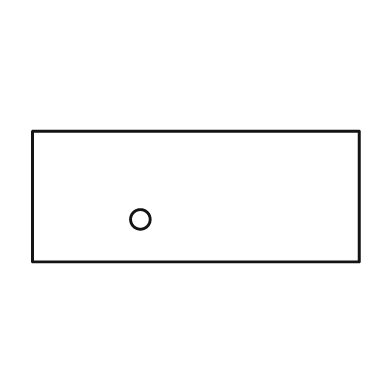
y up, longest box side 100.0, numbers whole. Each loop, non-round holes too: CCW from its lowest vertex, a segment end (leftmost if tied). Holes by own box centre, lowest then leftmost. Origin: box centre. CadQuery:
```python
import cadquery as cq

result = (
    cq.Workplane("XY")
    .moveTo(-50.0, -20.0)
    .lineTo(50.0, -20.0)
    .lineTo(50.0, 20.0)
    .lineTo(-50.0, 20.0)
    .close()
    .moveTo(-17.0, -7.0)
    .circle(3.0)
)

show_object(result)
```